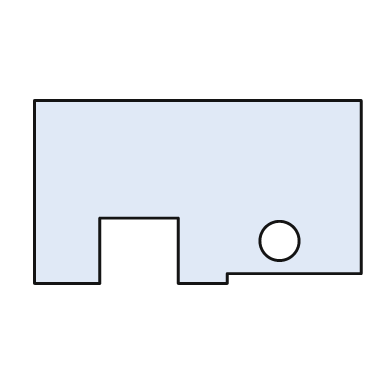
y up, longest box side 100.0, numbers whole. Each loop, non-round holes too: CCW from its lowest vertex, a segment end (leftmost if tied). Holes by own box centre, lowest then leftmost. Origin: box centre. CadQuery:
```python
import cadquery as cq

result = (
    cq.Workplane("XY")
    .moveTo(-50.0, -28.0)
    .lineTo(-30.0, -28.0)
    .lineTo(-30.0, -8.0)
    .lineTo(-6.0, -8.0)
    .lineTo(-6.0, -28.0)
    .lineTo(9.0, -28.0)
    .lineTo(9.0, -25.0)
    .lineTo(50.0, -25.0)
    .lineTo(50.0, 28.0)
    .lineTo(-50.0, 28.0)
    .close()
    .moveTo(25.0, -15.0)
    .circle(6.0)
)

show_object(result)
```